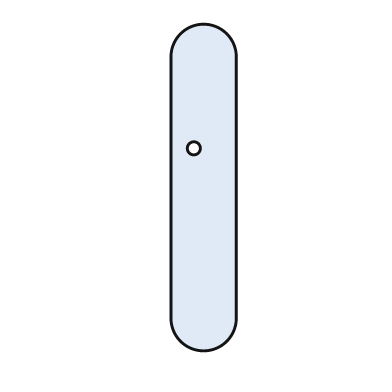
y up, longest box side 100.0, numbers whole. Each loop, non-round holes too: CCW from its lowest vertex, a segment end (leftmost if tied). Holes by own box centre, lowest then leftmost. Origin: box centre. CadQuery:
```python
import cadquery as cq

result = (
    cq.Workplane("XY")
    .moveTo(-10.0, -40.0)
    .threePointArc((0.0, -50.0), (10.0, -40.0))
    .lineTo(10.0, 40.0)
    .threePointArc((0.0, 50.0), (-10.0, 40.0))
    .close()
    .moveTo(-3.0, 12.0)
    .circle(2.0)
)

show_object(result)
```